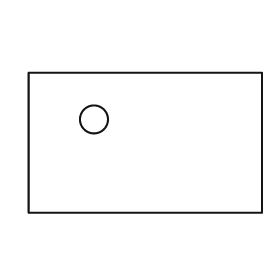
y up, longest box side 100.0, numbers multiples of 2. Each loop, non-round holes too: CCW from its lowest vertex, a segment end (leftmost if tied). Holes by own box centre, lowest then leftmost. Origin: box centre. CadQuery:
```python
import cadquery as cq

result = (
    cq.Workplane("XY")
    .moveTo(-50.0, -30.0)
    .lineTo(50.0, -30.0)
    .lineTo(50.0, 30.0)
    .lineTo(-50.0, 30.0)
    .close()
    .moveTo(-22.0, 10.0)
    .circle(6.0)
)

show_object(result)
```